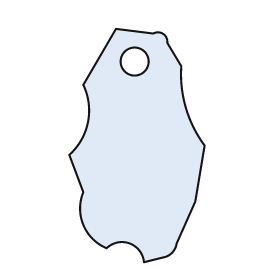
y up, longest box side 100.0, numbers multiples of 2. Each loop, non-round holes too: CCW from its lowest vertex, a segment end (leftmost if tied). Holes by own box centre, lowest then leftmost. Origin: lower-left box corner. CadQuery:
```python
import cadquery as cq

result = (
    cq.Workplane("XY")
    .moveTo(32.0, 0.0)
    .lineTo(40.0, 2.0)
    .threePointArc((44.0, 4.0), (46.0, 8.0))
    .lineTo(54.0, 26.0)
    .lineTo(58.0, 50.0)
    .threePointArc((50.0, 66.0), (48.0, 84.0))
    .lineTo(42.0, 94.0)
    .threePointArc((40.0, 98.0), (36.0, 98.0))
    .lineTo(20.0, 100.0)
    .lineTo(6.0, 76.0)
    .threePointArc((8.0, 60.0), (0.0, 46.0))
    .lineTo(6.0, 30.0)
    .threePointArc((6.0, 16.0), (16.0, 6.0))
    .threePointArc((26.0, 8.0), (32.0, 0.0))
    .close()
    .moveTo(28.0, 86.0)
    .circle(6.0)
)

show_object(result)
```